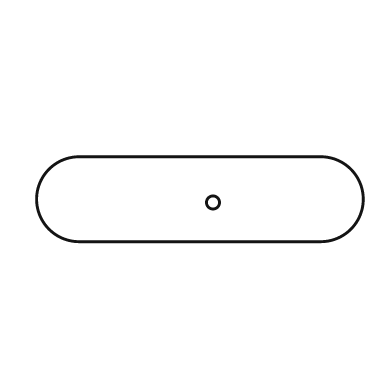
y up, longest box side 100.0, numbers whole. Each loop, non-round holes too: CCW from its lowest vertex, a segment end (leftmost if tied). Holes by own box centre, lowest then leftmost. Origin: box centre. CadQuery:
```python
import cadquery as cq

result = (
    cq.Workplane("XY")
    .moveTo(-37.0, -13.0)
    .lineTo(37.0, -13.0)
    .threePointArc((50.0, 0.0), (37.0, 13.0))
    .lineTo(-37.0, 13.0)
    .threePointArc((-50.0, 0.0), (-37.0, -13.0))
    .close()
    .moveTo(4.0, -1.0)
    .circle(2.0)
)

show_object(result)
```